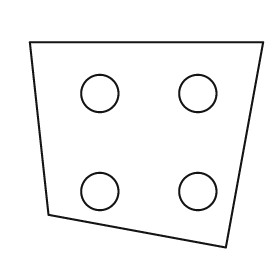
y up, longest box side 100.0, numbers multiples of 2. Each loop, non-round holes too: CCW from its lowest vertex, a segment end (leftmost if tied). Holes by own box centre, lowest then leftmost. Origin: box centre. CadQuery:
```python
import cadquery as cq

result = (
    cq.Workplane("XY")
    .moveTo(34.0, -44.0)
    .lineTo(50.0, 44.0)
    .lineTo(-50.0, 44.0)
    .lineTo(-42.0, -30.0)
    .close()
    .moveTo(-20.0, -20.0)
    .circle(8.0)
    .moveTo(22.0, -20.0)
    .circle(8.0)
    .moveTo(-20.0, 22.0)
    .circle(8.0)
    .moveTo(22.0, 22.0)
    .circle(8.0)
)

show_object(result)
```